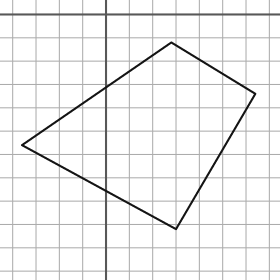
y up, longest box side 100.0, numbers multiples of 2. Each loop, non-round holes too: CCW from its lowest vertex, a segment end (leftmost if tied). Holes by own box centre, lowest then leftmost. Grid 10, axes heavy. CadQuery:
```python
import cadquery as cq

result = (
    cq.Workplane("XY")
    .moveTo(30.0, -92.0)
    .lineTo(64.0, -34.0)
    .lineTo(28.0, -12.0)
    .lineTo(-36.0, -56.0)
    .close()
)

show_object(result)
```